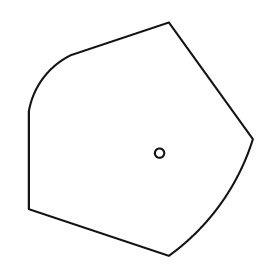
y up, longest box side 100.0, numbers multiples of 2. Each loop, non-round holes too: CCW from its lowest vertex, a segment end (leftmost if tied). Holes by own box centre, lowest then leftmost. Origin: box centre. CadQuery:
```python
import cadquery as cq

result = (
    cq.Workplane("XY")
    .moveTo(12.0, -50.0)
    .threePointArc((34.0, -28.0), (48.0, 0.0))
    .lineTo(12.0, 50.0)
    .lineTo(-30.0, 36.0)
    .threePointArc((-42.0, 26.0), (-48.0, 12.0))
    .lineTo(-48.0, -30.0)
    .close()
    .moveTo(8.0, -6.0)
    .circle(2.0)
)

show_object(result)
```